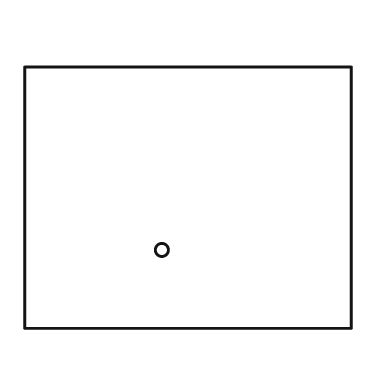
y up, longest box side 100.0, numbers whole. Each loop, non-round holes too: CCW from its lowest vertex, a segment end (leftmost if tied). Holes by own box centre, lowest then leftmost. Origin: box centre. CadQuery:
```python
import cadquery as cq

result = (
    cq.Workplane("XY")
    .moveTo(-50.0, -40.0)
    .lineTo(50.0, -40.0)
    .lineTo(50.0, 40.0)
    .lineTo(-50.0, 40.0)
    .close()
    .moveTo(-8.0, -16.0)
    .circle(2.0)
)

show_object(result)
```